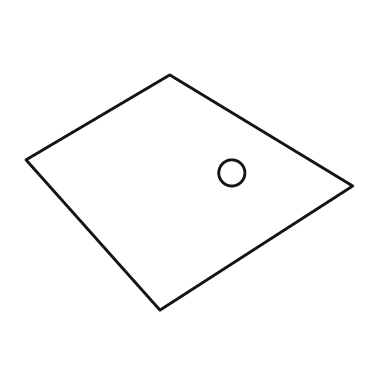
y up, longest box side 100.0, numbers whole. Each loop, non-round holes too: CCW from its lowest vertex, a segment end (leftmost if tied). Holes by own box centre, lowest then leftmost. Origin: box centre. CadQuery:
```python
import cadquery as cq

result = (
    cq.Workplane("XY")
    .moveTo(-9.0, -36.0)
    .lineTo(50.0, 2.0)
    .lineTo(-6.0, 36.0)
    .lineTo(-50.0, 10.0)
    .close()
    .moveTo(13.0, 6.0)
    .circle(4.0)
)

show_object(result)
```